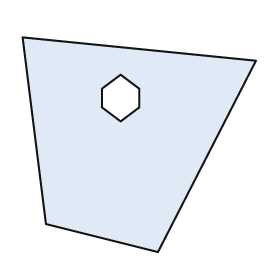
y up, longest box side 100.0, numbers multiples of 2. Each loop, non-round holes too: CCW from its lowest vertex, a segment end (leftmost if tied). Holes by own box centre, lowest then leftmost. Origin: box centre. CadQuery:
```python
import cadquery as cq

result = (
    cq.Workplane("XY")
    .moveTo(8.0, -46.0)
    .lineTo(50.0, 36.0)
    .lineTo(-50.0, 46.0)
    .lineTo(-40.0, -34.0)
    .close()
    .moveTo(-8.0, 10.0)
    .lineTo(0.0, 16.0)
    .lineTo(0.0, 24.0)
    .lineTo(-8.0, 30.0)
    .lineTo(-16.0, 24.0)
    .lineTo(-16.0, 16.0)
    .close()
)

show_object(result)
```